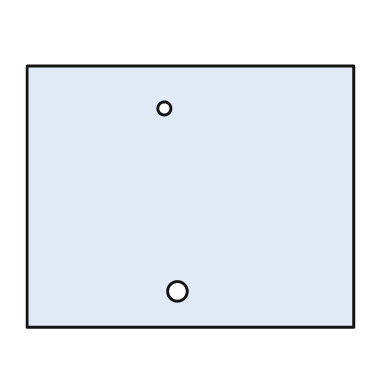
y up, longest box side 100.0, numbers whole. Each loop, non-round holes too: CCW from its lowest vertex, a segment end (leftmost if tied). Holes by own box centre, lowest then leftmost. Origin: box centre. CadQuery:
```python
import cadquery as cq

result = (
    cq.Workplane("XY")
    .moveTo(-50.0, -40.0)
    .lineTo(50.0, -40.0)
    .lineTo(50.0, 40.0)
    .lineTo(-50.0, 40.0)
    .close()
    .moveTo(-4.0, -29.0)
    .circle(3.0)
    .moveTo(-8.0, 27.0)
    .circle(2.0)
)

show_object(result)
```